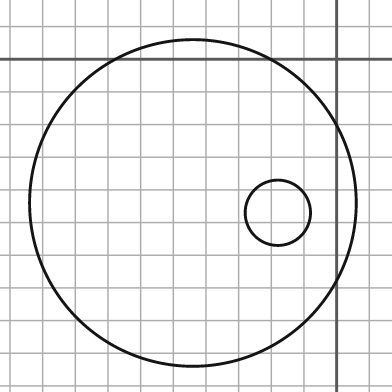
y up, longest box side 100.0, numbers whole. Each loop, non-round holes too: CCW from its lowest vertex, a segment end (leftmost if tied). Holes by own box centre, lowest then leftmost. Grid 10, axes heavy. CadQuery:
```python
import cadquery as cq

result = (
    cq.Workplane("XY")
    .moveTo(-44.0, -44.0)
    .circle(50.0)
    .moveTo(-18.0, -47.0)
    .circle(10.0)
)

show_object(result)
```